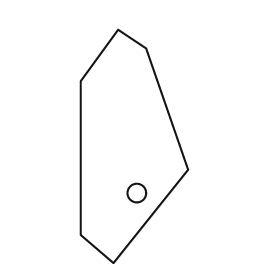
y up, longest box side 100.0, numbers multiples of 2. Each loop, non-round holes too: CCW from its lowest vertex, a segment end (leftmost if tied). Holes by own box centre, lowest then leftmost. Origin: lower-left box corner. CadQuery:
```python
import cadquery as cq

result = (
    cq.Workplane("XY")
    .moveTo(14.0, 0.0)
    .lineTo(46.0, 40.0)
    .lineTo(28.0, 92.0)
    .lineTo(16.0, 100.0)
    .lineTo(0.0, 78.0)
    .lineTo(0.0, 12.0)
    .close()
    .moveTo(24.0, 30.0)
    .circle(4.0)
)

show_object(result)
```